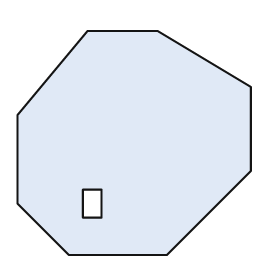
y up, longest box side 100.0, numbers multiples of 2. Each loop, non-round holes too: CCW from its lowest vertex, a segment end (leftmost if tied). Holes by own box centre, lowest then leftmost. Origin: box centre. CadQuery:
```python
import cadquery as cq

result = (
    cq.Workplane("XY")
    .moveTo(-28.0, -48.0)
    .lineTo(14.0, -48.0)
    .lineTo(50.0, -12.0)
    .lineTo(50.0, 24.0)
    .lineTo(10.0, 48.0)
    .lineTo(-20.0, 48.0)
    .lineTo(-50.0, 12.0)
    .lineTo(-50.0, -26.0)
    .close()
    .moveTo(-22.0, -32.0)
    .lineTo(-14.0, -32.0)
    .lineTo(-14.0, -20.0)
    .lineTo(-22.0, -20.0)
    .close()
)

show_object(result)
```